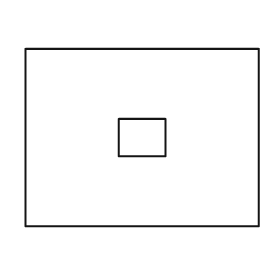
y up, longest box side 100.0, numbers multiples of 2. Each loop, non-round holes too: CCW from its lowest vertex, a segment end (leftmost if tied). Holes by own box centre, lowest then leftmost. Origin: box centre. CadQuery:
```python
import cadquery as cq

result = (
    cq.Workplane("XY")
    .moveTo(-50.0, -38.0)
    .lineTo(50.0, -38.0)
    .lineTo(50.0, 38.0)
    .lineTo(-50.0, 38.0)
    .close()
    .moveTo(-10.0, -8.0)
    .lineTo(10.0, -8.0)
    .lineTo(10.0, 8.0)
    .lineTo(-10.0, 8.0)
    .close()
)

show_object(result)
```